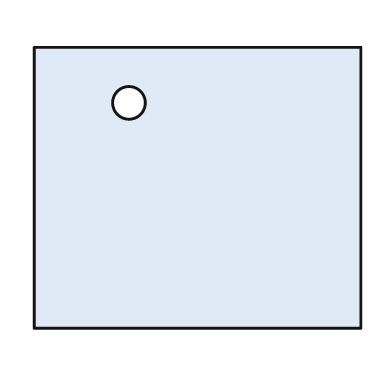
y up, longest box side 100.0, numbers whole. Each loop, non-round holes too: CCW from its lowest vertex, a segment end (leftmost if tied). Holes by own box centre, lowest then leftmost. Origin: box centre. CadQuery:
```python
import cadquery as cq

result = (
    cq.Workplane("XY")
    .moveTo(-50.0, -43.0)
    .lineTo(50.0, -43.0)
    .lineTo(50.0, 43.0)
    .lineTo(-50.0, 43.0)
    .close()
    .moveTo(-21.0, 26.0)
    .circle(5.0)
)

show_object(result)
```